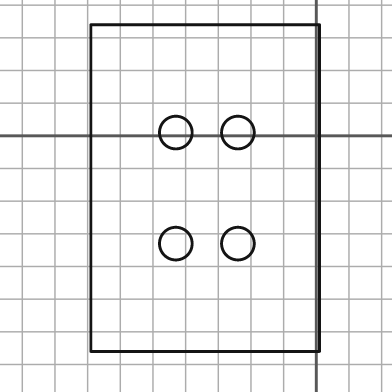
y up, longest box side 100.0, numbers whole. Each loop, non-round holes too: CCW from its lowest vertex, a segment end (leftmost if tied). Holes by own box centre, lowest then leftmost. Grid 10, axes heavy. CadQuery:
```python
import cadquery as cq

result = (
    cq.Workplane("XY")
    .moveTo(-69.0, -66.0)
    .lineTo(1.0, -66.0)
    .lineTo(1.0, 34.0)
    .lineTo(-69.0, 34.0)
    .close()
    .moveTo(-43.0, -33.0)
    .circle(5.0)
    .moveTo(-24.0, -33.0)
    .circle(5.0)
    .moveTo(-43.0, 1.0)
    .circle(5.0)
    .moveTo(-24.0, 1.0)
    .circle(5.0)
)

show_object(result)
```